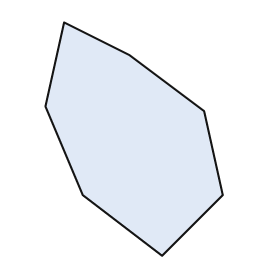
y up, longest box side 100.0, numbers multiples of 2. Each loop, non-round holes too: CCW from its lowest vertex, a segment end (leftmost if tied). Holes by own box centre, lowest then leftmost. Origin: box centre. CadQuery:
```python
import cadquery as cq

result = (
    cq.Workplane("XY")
    .moveTo(12.0, -50.0)
    .lineTo(38.0, -24.0)
    .lineTo(30.0, 12.0)
    .lineTo(-2.0, 36.0)
    .lineTo(-30.0, 50.0)
    .lineTo(-38.0, 14.0)
    .lineTo(-22.0, -24.0)
    .close()
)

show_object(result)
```